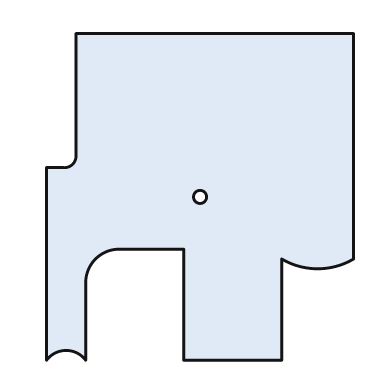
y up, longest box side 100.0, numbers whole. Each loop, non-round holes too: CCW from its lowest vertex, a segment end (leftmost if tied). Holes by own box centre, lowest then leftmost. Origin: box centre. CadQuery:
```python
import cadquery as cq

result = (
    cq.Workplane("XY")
    .moveTo(-47.0, -50.0)
    .threePointArc((-41.0, -47.0), (-35.0, -50.0))
    .lineTo(-35.0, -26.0)
    .threePointArc((-32.0, -19.0), (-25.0, -16.0))
    .lineTo(-5.0, -16.0)
    .lineTo(-5.0, -50.0)
    .lineTo(25.0, -50.0)
    .lineTo(25.0, -19.0)
    .threePointArc((36.0, -22.0), (47.0, -19.0))
    .lineTo(47.0, 50.0)
    .lineTo(-38.0, 50.0)
    .lineTo(-38.0, 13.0)
    .threePointArc((-39.0, 10.0), (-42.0, 9.0))
    .lineTo(-47.0, 9.0)
    .close()
    .moveTo(0.0, 0.0)
    .circle(2.0)
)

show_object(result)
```